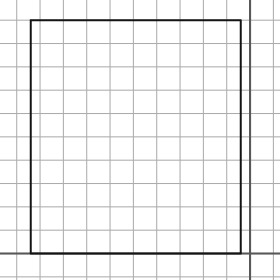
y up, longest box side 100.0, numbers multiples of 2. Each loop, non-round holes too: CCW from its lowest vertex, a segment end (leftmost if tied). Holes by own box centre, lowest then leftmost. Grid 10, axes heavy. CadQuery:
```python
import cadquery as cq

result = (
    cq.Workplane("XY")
    .moveTo(-94.0, 0.0)
    .lineTo(-4.0, 0.0)
    .lineTo(-4.0, 100.0)
    .lineTo(-94.0, 100.0)
    .close()
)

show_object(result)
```